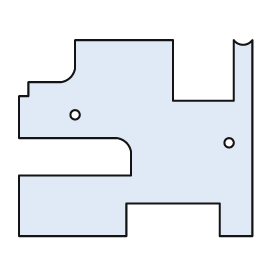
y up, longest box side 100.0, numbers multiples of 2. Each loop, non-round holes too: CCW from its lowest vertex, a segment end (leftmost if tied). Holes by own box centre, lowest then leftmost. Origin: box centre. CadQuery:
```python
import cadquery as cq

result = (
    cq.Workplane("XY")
    .moveTo(-50.0, -42.0)
    .lineTo(-4.0, -42.0)
    .lineTo(-4.0, -28.0)
    .lineTo(36.0, -28.0)
    .lineTo(36.0, -42.0)
    .lineTo(50.0, -42.0)
    .lineTo(50.0, 42.0)
    .threePointArc((46.0, 40.0), (42.0, 42.0))
    .lineTo(42.0, 16.0)
    .lineTo(16.0, 16.0)
    .lineTo(16.0, 42.0)
    .lineTo(-26.0, 42.0)
    .lineTo(-26.0, 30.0)
    .threePointArc((-28.0, 26.0), (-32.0, 24.0))
    .lineTo(-46.0, 24.0)
    .lineTo(-46.0, 18.0)
    .lineTo(-50.0, 18.0)
    .lineTo(-50.0, 0.0)
    .lineTo(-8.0, 0.0)
    .threePointArc((-4.0, -2.0), (-2.0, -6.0))
    .lineTo(-2.0, -16.0)
    .lineTo(-50.0, -16.0)
    .close()
    .moveTo(40.0, -2.0)
    .circle(2.0)
    .moveTo(-26.0, 10.0)
    .circle(2.0)
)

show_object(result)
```